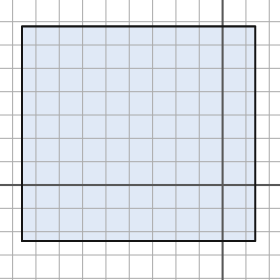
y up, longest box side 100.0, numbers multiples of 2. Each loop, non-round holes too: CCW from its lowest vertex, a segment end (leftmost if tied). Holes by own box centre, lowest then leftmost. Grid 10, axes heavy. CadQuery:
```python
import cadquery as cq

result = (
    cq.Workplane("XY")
    .moveTo(-86.0, -24.0)
    .lineTo(14.0, -24.0)
    .lineTo(14.0, 68.0)
    .lineTo(-86.0, 68.0)
    .close()
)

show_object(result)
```